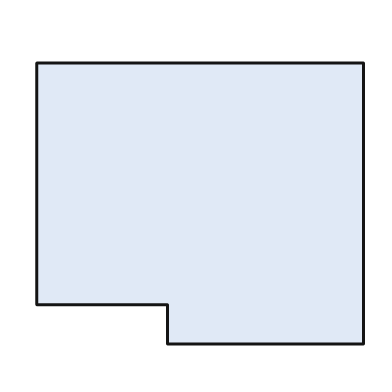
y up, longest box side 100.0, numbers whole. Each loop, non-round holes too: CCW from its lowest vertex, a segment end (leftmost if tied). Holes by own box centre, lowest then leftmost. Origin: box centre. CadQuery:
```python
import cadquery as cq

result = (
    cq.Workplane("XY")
    .moveTo(-10.0, -43.0)
    .lineTo(50.0, -43.0)
    .lineTo(50.0, 43.0)
    .lineTo(-50.0, 43.0)
    .lineTo(-50.0, -31.0)
    .lineTo(-10.0, -31.0)
    .close()
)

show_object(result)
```